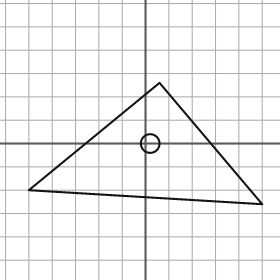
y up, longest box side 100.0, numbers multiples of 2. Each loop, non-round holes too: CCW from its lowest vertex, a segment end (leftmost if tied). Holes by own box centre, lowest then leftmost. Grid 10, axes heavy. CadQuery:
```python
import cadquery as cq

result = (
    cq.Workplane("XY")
    .moveTo(50.0, -26.0)
    .lineTo(6.0, 26.0)
    .lineTo(-50.0, -20.0)
    .close()
    .moveTo(2.0, 0.0)
    .circle(4.0)
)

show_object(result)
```